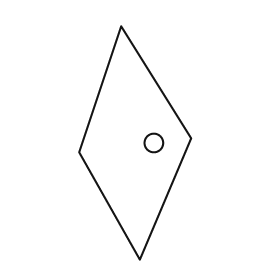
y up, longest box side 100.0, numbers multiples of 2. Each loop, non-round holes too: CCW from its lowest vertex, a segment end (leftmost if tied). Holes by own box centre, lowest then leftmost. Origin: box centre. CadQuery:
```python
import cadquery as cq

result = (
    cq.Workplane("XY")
    .moveTo(2.0, -50.0)
    .lineTo(24.0, 2.0)
    .lineTo(-6.0, 50.0)
    .lineTo(-24.0, -4.0)
    .close()
    .moveTo(8.0, 0.0)
    .circle(4.0)
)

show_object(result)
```